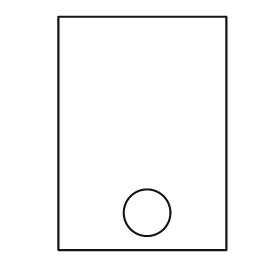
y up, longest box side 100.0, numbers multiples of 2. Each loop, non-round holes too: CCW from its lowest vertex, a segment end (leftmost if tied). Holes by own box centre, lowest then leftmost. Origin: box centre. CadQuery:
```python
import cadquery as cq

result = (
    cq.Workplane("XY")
    .moveTo(-36.0, -50.0)
    .lineTo(36.0, -50.0)
    .lineTo(36.0, 50.0)
    .lineTo(-36.0, 50.0)
    .close()
    .moveTo(2.0, -34.0)
    .circle(10.0)
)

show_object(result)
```